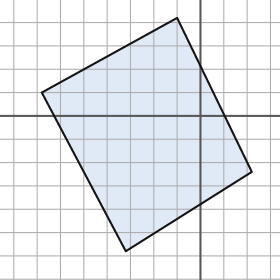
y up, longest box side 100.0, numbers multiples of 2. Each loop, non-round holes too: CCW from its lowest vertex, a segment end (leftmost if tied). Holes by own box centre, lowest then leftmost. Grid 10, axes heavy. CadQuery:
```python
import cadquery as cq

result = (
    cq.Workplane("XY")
    .moveTo(-32.0, -58.0)
    .lineTo(22.0, -24.0)
    .lineTo(-10.0, 42.0)
    .lineTo(-68.0, 10.0)
    .close()
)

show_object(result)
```